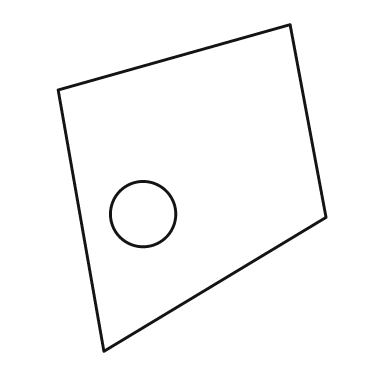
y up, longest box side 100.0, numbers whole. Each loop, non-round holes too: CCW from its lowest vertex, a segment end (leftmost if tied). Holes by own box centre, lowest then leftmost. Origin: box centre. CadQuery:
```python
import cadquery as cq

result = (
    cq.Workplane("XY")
    .moveTo(-27.0, -50.0)
    .lineTo(41.0, -9.0)
    .lineTo(30.0, 50.0)
    .lineTo(-41.0, 30.0)
    .close()
    .moveTo(-15.0, -8.0)
    .circle(10.0)
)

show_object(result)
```